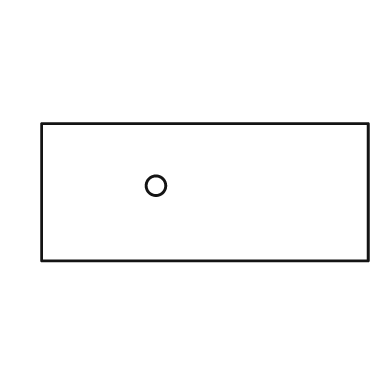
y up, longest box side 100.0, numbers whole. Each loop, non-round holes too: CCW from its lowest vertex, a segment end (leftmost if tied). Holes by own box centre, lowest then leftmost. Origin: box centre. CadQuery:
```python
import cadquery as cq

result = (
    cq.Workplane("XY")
    .moveTo(-50.0, -21.0)
    .lineTo(50.0, -21.0)
    .lineTo(50.0, 21.0)
    .lineTo(-50.0, 21.0)
    .close()
    .moveTo(-15.0, 2.0)
    .circle(3.0)
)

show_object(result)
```